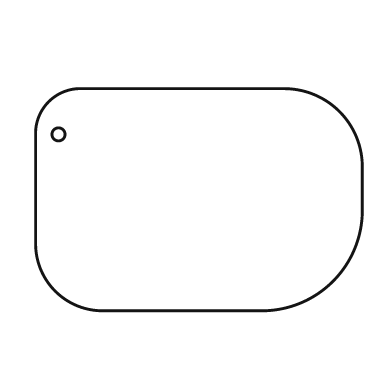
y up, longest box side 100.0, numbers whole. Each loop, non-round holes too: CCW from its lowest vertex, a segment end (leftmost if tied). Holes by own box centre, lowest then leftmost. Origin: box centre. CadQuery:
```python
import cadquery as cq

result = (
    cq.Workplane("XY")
    .moveTo(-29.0, -34.0)
    .lineTo(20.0, -34.0)
    .threePointArc((41.0, -25.0), (50.0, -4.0))
    .lineTo(50.0, 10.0)
    .threePointArc((43.0, 27.0), (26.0, 34.0))
    .lineTo(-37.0, 34.0)
    .threePointArc((-46.0, 30.0), (-50.0, 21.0))
    .lineTo(-50.0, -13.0)
    .threePointArc((-44.0, -28.0), (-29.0, -34.0))
    .close()
    .moveTo(-43.0, 20.0)
    .circle(2.0)
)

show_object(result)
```